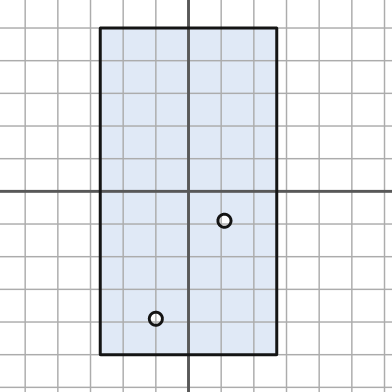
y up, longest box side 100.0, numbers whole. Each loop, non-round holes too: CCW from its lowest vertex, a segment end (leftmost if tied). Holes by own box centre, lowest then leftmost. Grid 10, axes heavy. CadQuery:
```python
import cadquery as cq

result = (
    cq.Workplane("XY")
    .moveTo(-27.0, -50.0)
    .lineTo(27.0, -50.0)
    .lineTo(27.0, 50.0)
    .lineTo(-27.0, 50.0)
    .close()
    .moveTo(-10.0, -39.0)
    .circle(2.0)
    .moveTo(11.0, -9.0)
    .circle(2.0)
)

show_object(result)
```